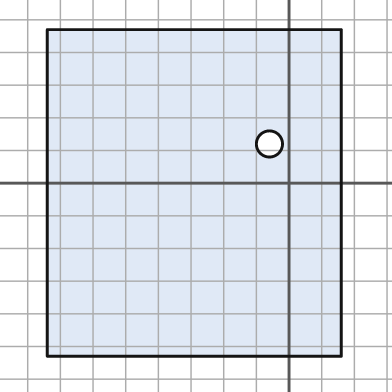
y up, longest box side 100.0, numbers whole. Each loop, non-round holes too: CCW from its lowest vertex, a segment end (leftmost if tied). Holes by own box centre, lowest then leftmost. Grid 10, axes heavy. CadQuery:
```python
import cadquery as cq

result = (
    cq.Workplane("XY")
    .moveTo(-74.0, -53.0)
    .lineTo(16.0, -53.0)
    .lineTo(16.0, 47.0)
    .lineTo(-74.0, 47.0)
    .close()
    .moveTo(-6.0, 12.0)
    .circle(4.0)
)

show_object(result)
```